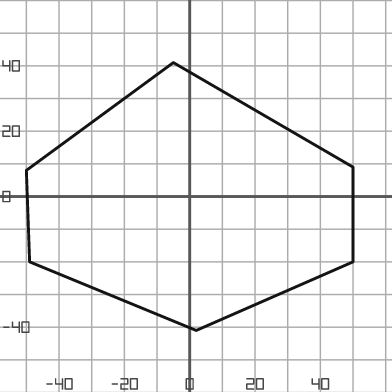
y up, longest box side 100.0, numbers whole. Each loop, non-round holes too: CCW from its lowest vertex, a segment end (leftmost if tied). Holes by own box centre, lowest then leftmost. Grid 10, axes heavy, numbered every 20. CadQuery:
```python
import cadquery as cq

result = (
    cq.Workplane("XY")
    .moveTo(2.0, -41.0)
    .lineTo(50.0, -20.0)
    .lineTo(50.0, 9.0)
    .lineTo(-5.0, 41.0)
    .lineTo(-50.0, 8.0)
    .lineTo(-49.0, -20.0)
    .close()
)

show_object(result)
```